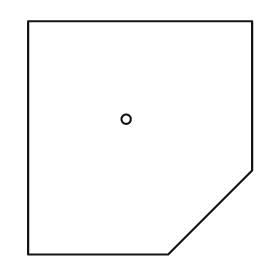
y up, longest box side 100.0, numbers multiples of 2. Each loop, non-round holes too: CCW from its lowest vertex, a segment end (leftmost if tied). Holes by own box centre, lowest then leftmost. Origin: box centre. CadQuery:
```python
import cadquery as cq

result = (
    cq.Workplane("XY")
    .moveTo(-48.0, -50.0)
    .lineTo(12.0, -50.0)
    .lineTo(48.0, -14.0)
    .lineTo(48.0, 50.0)
    .lineTo(-48.0, 50.0)
    .close()
    .moveTo(-6.0, 8.0)
    .circle(2.0)
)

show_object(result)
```